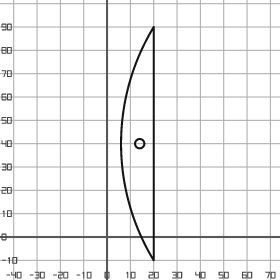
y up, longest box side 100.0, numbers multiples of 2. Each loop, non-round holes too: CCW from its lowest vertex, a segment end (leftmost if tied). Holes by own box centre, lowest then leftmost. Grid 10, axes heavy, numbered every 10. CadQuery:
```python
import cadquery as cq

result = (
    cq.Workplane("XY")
    .moveTo(20.0, -10.0)
    .lineTo(20.0, 90.0)
    .threePointArc((6.0, 40.0), (20.0, -10.0))
    .close()
    .moveTo(14.0, 40.0)
    .circle(2.0)
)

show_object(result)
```